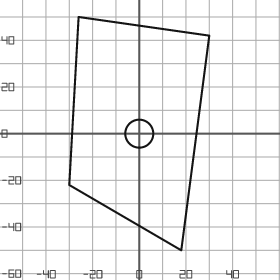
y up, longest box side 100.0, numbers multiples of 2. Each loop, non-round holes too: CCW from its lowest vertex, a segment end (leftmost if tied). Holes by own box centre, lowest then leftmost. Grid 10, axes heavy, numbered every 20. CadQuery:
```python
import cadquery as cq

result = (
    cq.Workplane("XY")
    .moveTo(18.0, -50.0)
    .lineTo(30.0, 42.0)
    .lineTo(-26.0, 50.0)
    .lineTo(-30.0, -22.0)
    .close()
    .moveTo(0.0, 0.0)
    .circle(6.0)
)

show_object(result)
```